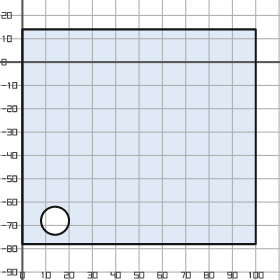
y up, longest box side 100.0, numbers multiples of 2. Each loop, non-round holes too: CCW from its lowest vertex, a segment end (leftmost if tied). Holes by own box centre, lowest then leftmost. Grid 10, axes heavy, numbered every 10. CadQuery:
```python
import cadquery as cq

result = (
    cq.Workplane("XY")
    .moveTo(0.0, -78.0)
    .lineTo(100.0, -78.0)
    .lineTo(100.0, 14.0)
    .lineTo(0.0, 14.0)
    .close()
    .moveTo(14.0, -68.0)
    .circle(6.0)
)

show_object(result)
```